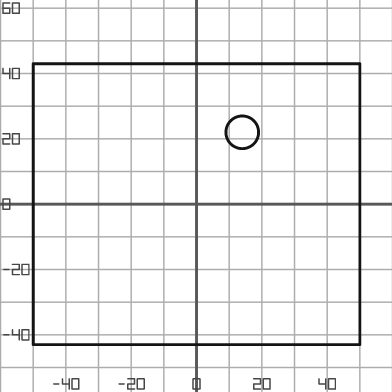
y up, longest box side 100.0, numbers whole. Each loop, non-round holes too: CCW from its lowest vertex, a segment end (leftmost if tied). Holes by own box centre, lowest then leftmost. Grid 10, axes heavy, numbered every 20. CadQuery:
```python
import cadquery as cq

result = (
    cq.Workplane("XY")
    .moveTo(-50.0, -43.0)
    .lineTo(50.0, -43.0)
    .lineTo(50.0, 43.0)
    .lineTo(-50.0, 43.0)
    .close()
    .moveTo(14.0, 22.0)
    .circle(5.0)
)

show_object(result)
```